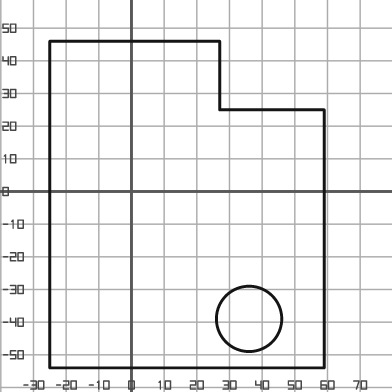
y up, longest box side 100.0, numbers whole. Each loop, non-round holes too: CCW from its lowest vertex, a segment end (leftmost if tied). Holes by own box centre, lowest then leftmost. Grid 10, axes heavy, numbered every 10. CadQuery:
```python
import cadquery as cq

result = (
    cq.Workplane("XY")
    .moveTo(-25.0, -54.0)
    .lineTo(59.0, -54.0)
    .lineTo(59.0, 25.0)
    .lineTo(27.0, 25.0)
    .lineTo(27.0, 46.0)
    .lineTo(-25.0, 46.0)
    .close()
    .moveTo(36.0, -39.0)
    .circle(10.0)
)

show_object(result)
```